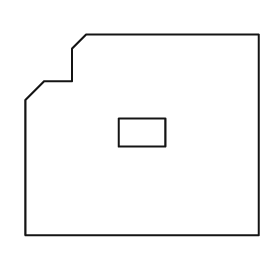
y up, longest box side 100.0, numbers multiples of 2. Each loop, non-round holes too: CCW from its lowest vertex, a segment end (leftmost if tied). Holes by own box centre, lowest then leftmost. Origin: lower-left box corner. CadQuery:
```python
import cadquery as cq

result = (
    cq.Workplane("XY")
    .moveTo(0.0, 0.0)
    .lineTo(100.0, 0.0)
    .lineTo(100.0, 86.0)
    .lineTo(26.0, 86.0)
    .lineTo(20.0, 80.0)
    .lineTo(20.0, 66.0)
    .lineTo(8.0, 66.0)
    .lineTo(0.0, 58.0)
    .close()
    .moveTo(40.0, 38.0)
    .lineTo(60.0, 38.0)
    .lineTo(60.0, 50.0)
    .lineTo(40.0, 50.0)
    .close()
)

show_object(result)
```